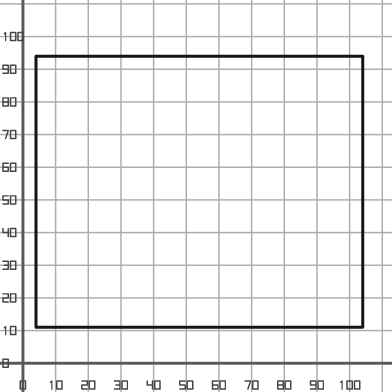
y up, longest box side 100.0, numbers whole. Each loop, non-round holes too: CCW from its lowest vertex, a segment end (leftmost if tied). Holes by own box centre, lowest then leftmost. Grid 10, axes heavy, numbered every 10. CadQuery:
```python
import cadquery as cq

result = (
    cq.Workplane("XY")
    .moveTo(4.0, 11.0)
    .lineTo(104.0, 11.0)
    .lineTo(104.0, 94.0)
    .lineTo(4.0, 94.0)
    .close()
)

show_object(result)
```